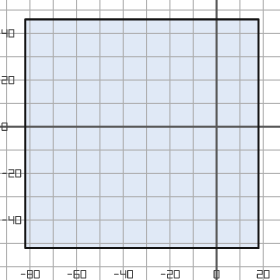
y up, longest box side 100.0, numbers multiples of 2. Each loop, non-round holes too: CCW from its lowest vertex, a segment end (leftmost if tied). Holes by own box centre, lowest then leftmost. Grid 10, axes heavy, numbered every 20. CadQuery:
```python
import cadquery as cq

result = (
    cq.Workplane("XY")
    .moveTo(-82.0, -52.0)
    .lineTo(18.0, -52.0)
    .lineTo(18.0, 46.0)
    .lineTo(-82.0, 46.0)
    .close()
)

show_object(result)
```